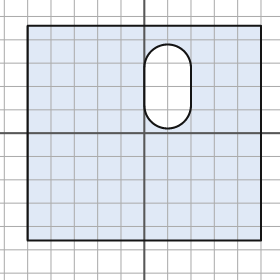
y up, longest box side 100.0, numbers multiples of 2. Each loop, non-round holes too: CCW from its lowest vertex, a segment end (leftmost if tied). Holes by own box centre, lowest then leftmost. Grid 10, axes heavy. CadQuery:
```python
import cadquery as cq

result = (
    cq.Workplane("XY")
    .moveTo(-50.0, -46.0)
    .lineTo(50.0, -46.0)
    .lineTo(50.0, 46.0)
    .lineTo(-50.0, 46.0)
    .close()
    .moveTo(0.0, 12.0)
    .threePointArc((10.0, 2.0), (20.0, 12.0))
    .lineTo(20.0, 28.0)
    .threePointArc((10.0, 38.0), (0.0, 28.0))
    .close()
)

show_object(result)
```